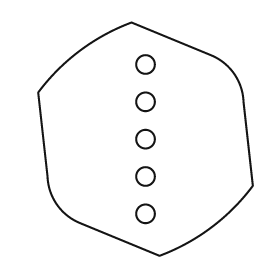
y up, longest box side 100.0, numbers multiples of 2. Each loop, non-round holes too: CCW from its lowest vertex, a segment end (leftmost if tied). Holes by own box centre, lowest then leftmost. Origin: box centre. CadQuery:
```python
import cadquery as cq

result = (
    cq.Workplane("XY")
    .moveTo(6.0, -50.0)
    .threePointArc((28.0, -38.0), (46.0, -20.0))
    .lineTo(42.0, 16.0)
    .threePointArc((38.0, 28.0), (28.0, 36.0))
    .lineTo(-6.0, 50.0)
    .threePointArc((-28.0, 38.0), (-46.0, 20.0))
    .lineTo(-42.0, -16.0)
    .threePointArc((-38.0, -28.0), (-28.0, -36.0))
    .close()
    .moveTo(0.0, -32.0)
    .circle(4.0)
    .moveTo(0.0, -16.0)
    .circle(4.0)
    .moveTo(0.0, 0.0)
    .circle(4.0)
    .moveTo(0.0, 16.0)
    .circle(4.0)
    .moveTo(0.0, 32.0)
    .circle(4.0)
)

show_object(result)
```